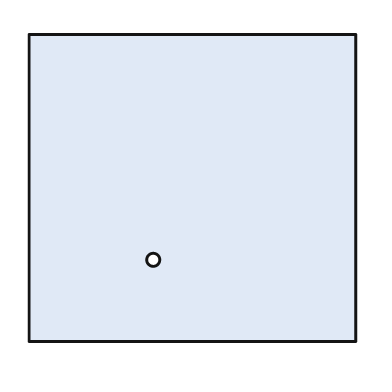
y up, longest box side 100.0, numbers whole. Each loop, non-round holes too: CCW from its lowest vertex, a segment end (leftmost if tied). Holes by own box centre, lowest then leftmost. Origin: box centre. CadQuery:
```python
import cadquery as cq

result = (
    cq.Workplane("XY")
    .moveTo(-50.0, -47.0)
    .lineTo(50.0, -47.0)
    .lineTo(50.0, 47.0)
    .lineTo(-50.0, 47.0)
    .close()
    .moveTo(-12.0, -22.0)
    .circle(2.0)
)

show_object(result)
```